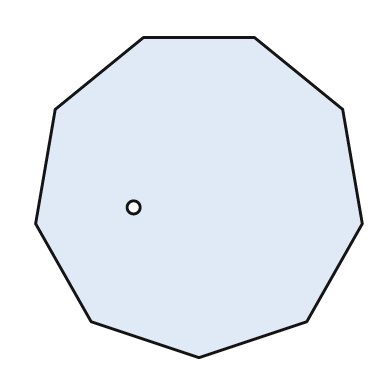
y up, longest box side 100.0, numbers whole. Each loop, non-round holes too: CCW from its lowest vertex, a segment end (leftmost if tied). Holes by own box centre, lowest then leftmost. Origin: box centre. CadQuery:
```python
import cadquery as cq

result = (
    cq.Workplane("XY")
    .moveTo(0.0, -49.0)
    .lineTo(33.0, -38.0)
    .lineTo(50.0, -8.0)
    .lineTo(44.0, 27.0)
    .lineTo(17.0, 49.0)
    .lineTo(-17.0, 49.0)
    .lineTo(-44.0, 27.0)
    .lineTo(-50.0, -8.0)
    .lineTo(-33.0, -38.0)
    .close()
    .moveTo(-20.0, -3.0)
    .circle(2.0)
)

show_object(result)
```